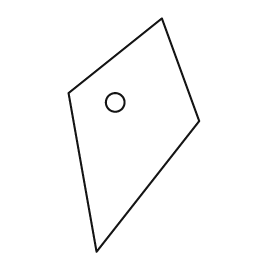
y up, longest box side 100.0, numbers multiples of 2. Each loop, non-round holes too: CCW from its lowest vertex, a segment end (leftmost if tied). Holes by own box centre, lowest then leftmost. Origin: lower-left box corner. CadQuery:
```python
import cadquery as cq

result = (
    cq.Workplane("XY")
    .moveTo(12.0, 0.0)
    .lineTo(56.0, 56.0)
    .lineTo(40.0, 100.0)
    .lineTo(0.0, 68.0)
    .close()
    .moveTo(20.0, 64.0)
    .circle(4.0)
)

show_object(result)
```